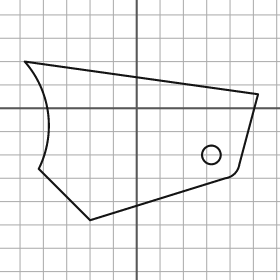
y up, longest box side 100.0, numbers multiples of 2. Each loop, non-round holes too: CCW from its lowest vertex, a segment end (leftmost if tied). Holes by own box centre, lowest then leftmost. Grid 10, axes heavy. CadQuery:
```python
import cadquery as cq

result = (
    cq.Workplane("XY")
    .moveTo(-20.0, -48.0)
    .lineTo(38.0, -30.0)
    .threePointArc((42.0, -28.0), (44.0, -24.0))
    .lineTo(52.0, 6.0)
    .lineTo(-48.0, 20.0)
    .threePointArc((-38.0, -2.0), (-42.0, -26.0))
    .close()
    .moveTo(32.0, -20.0)
    .circle(4.0)
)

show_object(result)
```